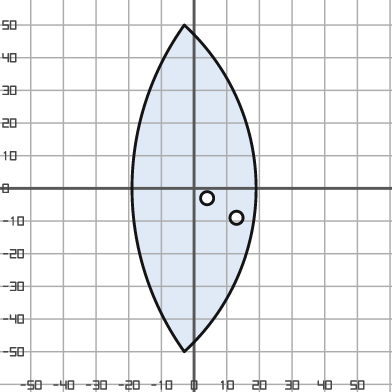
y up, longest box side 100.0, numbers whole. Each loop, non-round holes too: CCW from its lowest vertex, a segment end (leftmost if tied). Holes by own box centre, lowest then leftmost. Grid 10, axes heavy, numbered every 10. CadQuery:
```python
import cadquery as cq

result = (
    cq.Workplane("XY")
    .moveTo(-3.0, -50.0)
    .threePointArc((19.0, 0.0), (-3.0, 50.0))
    .threePointArc((-19.0, 0.0), (-3.0, -50.0))
    .close()
    .moveTo(13.0, -9.0)
    .circle(2.0)
    .moveTo(4.0, -3.0)
    .circle(2.0)
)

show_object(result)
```